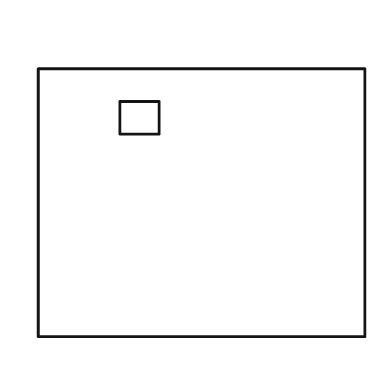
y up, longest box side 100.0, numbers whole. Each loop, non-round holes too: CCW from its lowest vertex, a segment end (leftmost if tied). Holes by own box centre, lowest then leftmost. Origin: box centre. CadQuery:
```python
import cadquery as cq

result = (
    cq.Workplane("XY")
    .moveTo(-50.0, -41.0)
    .lineTo(50.0, -41.0)
    .lineTo(50.0, 41.0)
    .lineTo(-50.0, 41.0)
    .close()
    .moveTo(-25.0, 21.0)
    .lineTo(-13.0, 21.0)
    .lineTo(-13.0, 31.0)
    .lineTo(-25.0, 31.0)
    .close()
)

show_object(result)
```